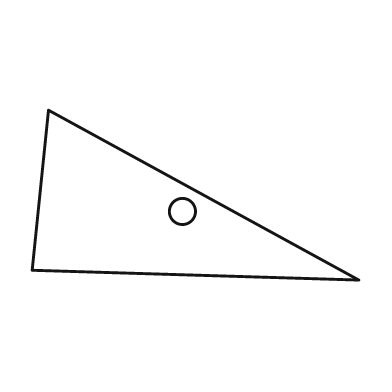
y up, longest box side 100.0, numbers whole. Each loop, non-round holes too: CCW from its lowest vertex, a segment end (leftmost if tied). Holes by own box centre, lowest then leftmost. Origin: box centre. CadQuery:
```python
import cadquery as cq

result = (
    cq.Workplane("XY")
    .moveTo(50.0, -26.0)
    .lineTo(-45.0, 26.0)
    .lineTo(-50.0, -23.0)
    .close()
    .moveTo(-4.0, -5.0)
    .circle(4.0)
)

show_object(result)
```